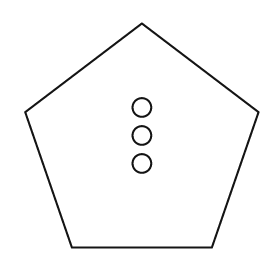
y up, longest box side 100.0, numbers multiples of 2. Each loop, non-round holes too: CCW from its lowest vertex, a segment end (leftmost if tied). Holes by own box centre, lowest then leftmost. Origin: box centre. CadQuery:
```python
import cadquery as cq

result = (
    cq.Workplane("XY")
    .moveTo(-30.0, -48.0)
    .lineTo(30.0, -48.0)
    .lineTo(50.0, 10.0)
    .lineTo(0.0, 48.0)
    .lineTo(-50.0, 10.0)
    .close()
    .moveTo(0.0, -12.0)
    .circle(4.0)
    .moveTo(0.0, 0.0)
    .circle(4.0)
    .moveTo(0.0, 12.0)
    .circle(4.0)
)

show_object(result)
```